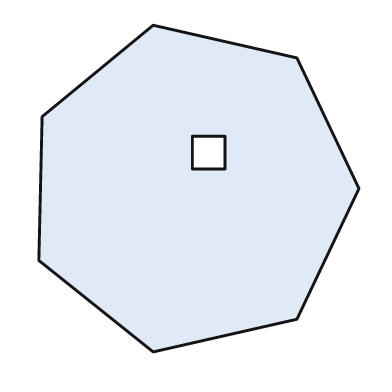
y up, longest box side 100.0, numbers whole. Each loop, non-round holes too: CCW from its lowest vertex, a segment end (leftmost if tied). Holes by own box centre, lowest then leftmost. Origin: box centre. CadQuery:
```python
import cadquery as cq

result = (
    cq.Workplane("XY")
    .moveTo(-14.0, -50.0)
    .lineTo(30.0, -40.0)
    .lineTo(49.0, 0.0)
    .lineTo(30.0, 40.0)
    .lineTo(-14.0, 50.0)
    .lineTo(-48.0, 22.0)
    .lineTo(-49.0, -22.0)
    .close()
    .moveTo(-2.0, 6.0)
    .lineTo(8.0, 6.0)
    .lineTo(8.0, 16.0)
    .lineTo(-2.0, 16.0)
    .close()
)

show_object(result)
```